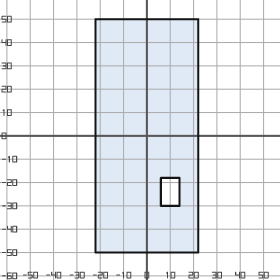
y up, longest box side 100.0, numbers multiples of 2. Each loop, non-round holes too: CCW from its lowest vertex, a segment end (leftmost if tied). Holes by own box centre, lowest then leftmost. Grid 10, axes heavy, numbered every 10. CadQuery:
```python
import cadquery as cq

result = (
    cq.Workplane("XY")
    .moveTo(-22.0, -50.0)
    .lineTo(22.0, -50.0)
    .lineTo(22.0, 50.0)
    .lineTo(-22.0, 50.0)
    .close()
    .moveTo(6.0, -30.0)
    .lineTo(14.0, -30.0)
    .lineTo(14.0, -18.0)
    .lineTo(6.0, -18.0)
    .close()
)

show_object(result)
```